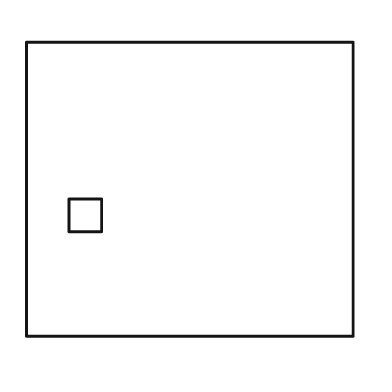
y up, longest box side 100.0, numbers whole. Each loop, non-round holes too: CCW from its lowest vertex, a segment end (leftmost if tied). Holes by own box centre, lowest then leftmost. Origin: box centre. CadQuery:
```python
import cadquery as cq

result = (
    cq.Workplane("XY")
    .moveTo(-50.0, -45.0)
    .lineTo(50.0, -45.0)
    .lineTo(50.0, 45.0)
    .lineTo(-50.0, 45.0)
    .close()
    .moveTo(-37.0, -13.0)
    .lineTo(-27.0, -13.0)
    .lineTo(-27.0, -3.0)
    .lineTo(-37.0, -3.0)
    .close()
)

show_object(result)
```